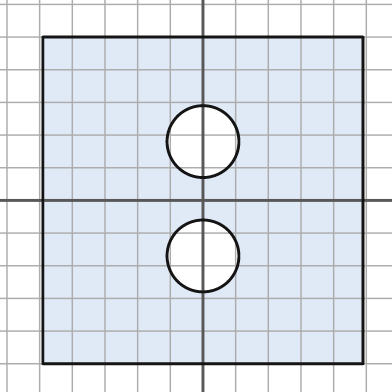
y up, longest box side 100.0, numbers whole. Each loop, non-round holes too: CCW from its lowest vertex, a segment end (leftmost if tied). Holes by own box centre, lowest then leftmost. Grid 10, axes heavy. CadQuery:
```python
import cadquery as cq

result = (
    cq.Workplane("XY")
    .moveTo(-49.0, -50.0)
    .lineTo(49.0, -50.0)
    .lineTo(49.0, 50.0)
    .lineTo(-49.0, 50.0)
    .close()
    .moveTo(0.0, -17.0)
    .circle(11.0)
    .moveTo(0.0, 18.0)
    .circle(11.0)
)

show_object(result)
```